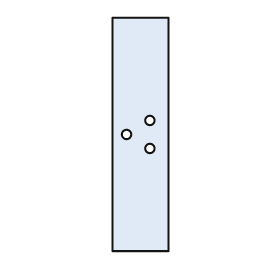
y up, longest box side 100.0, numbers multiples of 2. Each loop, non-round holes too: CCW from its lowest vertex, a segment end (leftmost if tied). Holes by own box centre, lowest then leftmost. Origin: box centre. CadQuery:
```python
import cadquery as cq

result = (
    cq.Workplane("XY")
    .moveTo(-12.0, -50.0)
    .lineTo(12.0, -50.0)
    .lineTo(12.0, 50.0)
    .lineTo(-12.0, 50.0)
    .close()
    .moveTo(4.0, -6.0)
    .circle(2.0)
    .moveTo(-6.0, 0.0)
    .circle(2.0)
    .moveTo(4.0, 6.0)
    .circle(2.0)
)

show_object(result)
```